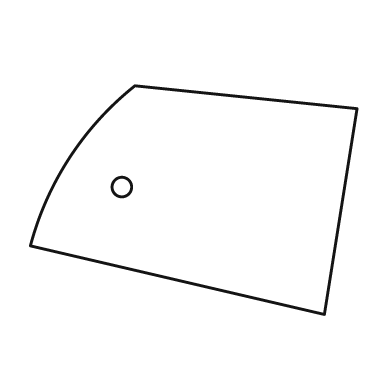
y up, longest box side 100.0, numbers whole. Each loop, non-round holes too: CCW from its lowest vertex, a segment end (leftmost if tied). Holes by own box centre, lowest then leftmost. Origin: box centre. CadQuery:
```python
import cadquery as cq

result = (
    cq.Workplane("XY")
    .moveTo(40.0, -35.0)
    .lineTo(50.0, 28.0)
    .lineTo(-18.0, 35.0)
    .threePointArc((-38.0, 13.0), (-50.0, -14.0))
    .close()
    .moveTo(-22.0, 4.0)
    .circle(3.0)
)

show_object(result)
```